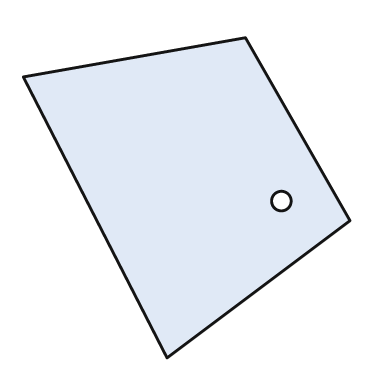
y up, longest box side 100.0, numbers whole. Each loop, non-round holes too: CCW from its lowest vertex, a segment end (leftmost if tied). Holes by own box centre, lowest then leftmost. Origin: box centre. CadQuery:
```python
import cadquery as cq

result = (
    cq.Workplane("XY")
    .moveTo(-6.0, -49.0)
    .lineTo(50.0, -7.0)
    .lineTo(18.0, 49.0)
    .lineTo(-50.0, 37.0)
    .close()
    .moveTo(29.0, -1.0)
    .circle(3.0)
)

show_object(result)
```